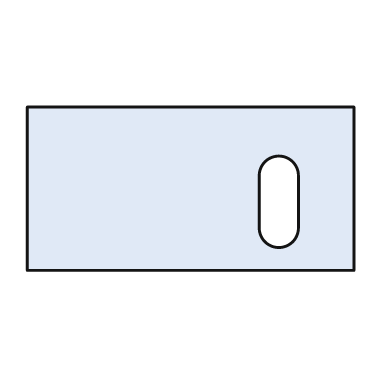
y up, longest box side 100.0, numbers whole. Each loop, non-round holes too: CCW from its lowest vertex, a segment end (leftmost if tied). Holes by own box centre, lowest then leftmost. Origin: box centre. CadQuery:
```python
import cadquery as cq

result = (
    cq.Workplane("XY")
    .moveTo(-50.0, -25.0)
    .lineTo(50.0, -25.0)
    .lineTo(50.0, 25.0)
    .lineTo(-50.0, 25.0)
    .close()
    .moveTo(21.0, -12.0)
    .threePointArc((27.0, -18.0), (33.0, -12.0))
    .lineTo(33.0, 4.0)
    .threePointArc((27.0, 10.0), (21.0, 4.0))
    .close()
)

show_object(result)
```